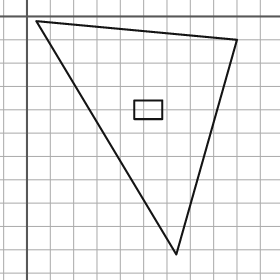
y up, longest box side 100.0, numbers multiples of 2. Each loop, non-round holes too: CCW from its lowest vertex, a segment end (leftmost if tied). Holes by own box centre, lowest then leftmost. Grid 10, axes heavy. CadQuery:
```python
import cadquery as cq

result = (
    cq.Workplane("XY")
    .moveTo(64.0, -102.0)
    .lineTo(90.0, -10.0)
    .lineTo(4.0, -2.0)
    .close()
    .moveTo(46.0, -44.0)
    .lineTo(58.0, -44.0)
    .lineTo(58.0, -36.0)
    .lineTo(46.0, -36.0)
    .close()
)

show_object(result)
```